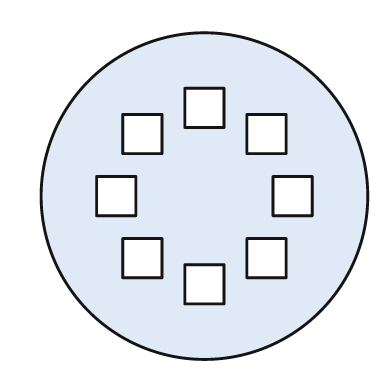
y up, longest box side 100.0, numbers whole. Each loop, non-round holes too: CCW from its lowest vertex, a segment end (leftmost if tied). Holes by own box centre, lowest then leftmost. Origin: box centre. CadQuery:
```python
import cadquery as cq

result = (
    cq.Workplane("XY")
    .moveTo(0.0, 0.0)
    .circle(50.0)
    .moveTo(-6.0, -33.0)
    .lineTo(6.0, -33.0)
    .lineTo(6.0, -21.0)
    .lineTo(-6.0, -21.0)
    .close()
    .moveTo(-25.0, -25.0)
    .lineTo(-13.0, -25.0)
    .lineTo(-13.0, -13.0)
    .lineTo(-25.0, -13.0)
    .close()
    .moveTo(13.0, -25.0)
    .lineTo(25.0, -25.0)
    .lineTo(25.0, -13.0)
    .lineTo(13.0, -13.0)
    .close()
    .moveTo(-33.0, -6.0)
    .lineTo(-21.0, -6.0)
    .lineTo(-21.0, 6.0)
    .lineTo(-33.0, 6.0)
    .close()
    .moveTo(21.0, -6.0)
    .lineTo(33.0, -6.0)
    .lineTo(33.0, 6.0)
    .lineTo(21.0, 6.0)
    .close()
    .moveTo(-25.0, 13.0)
    .lineTo(-13.0, 13.0)
    .lineTo(-13.0, 25.0)
    .lineTo(-25.0, 25.0)
    .close()
    .moveTo(13.0, 13.0)
    .lineTo(25.0, 13.0)
    .lineTo(25.0, 25.0)
    .lineTo(13.0, 25.0)
    .close()
    .moveTo(-6.0, 21.0)
    .lineTo(6.0, 21.0)
    .lineTo(6.0, 33.0)
    .lineTo(-6.0, 33.0)
    .close()
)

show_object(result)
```